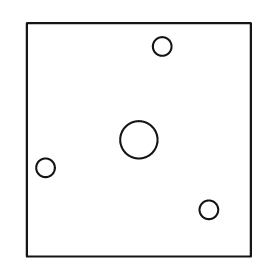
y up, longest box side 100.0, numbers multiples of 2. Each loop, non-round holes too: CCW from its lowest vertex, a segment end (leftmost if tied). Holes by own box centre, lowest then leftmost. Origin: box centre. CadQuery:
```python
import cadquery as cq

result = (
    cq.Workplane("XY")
    .moveTo(-48.0, -50.0)
    .lineTo(48.0, -50.0)
    .lineTo(48.0, 50.0)
    .lineTo(-48.0, 50.0)
    .close()
    .moveTo(30.0, -30.0)
    .circle(4.0)
    .moveTo(-40.0, -12.0)
    .circle(4.0)
    .moveTo(0.0, 0.0)
    .circle(8.0)
    .moveTo(10.0, 40.0)
    .circle(4.0)
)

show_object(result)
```